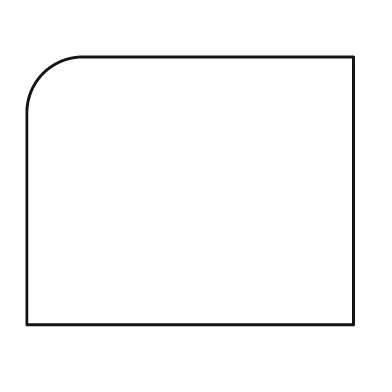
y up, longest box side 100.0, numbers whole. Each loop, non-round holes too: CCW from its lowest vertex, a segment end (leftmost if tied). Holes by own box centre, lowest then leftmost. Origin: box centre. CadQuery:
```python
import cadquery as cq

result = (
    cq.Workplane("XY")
    .moveTo(-50.0, -41.0)
    .lineTo(50.0, -41.0)
    .lineTo(50.0, 41.0)
    .lineTo(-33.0, 41.0)
    .threePointArc((-45.0, 36.0), (-50.0, 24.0))
    .close()
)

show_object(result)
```